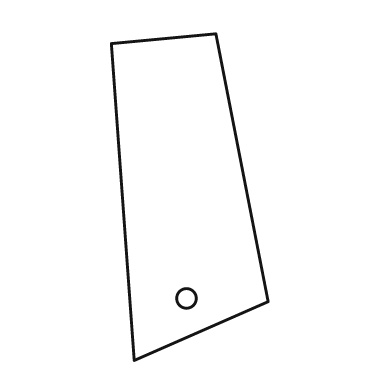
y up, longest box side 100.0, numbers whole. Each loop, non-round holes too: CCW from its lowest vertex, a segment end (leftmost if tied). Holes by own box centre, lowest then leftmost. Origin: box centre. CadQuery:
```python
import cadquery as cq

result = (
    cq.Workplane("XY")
    .moveTo(-17.0, -50.0)
    .lineTo(24.0, -32.0)
    .lineTo(8.0, 50.0)
    .lineTo(-24.0, 47.0)
    .close()
    .moveTo(-1.0, -31.0)
    .circle(3.0)
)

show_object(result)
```